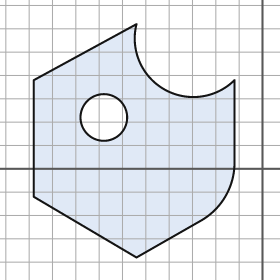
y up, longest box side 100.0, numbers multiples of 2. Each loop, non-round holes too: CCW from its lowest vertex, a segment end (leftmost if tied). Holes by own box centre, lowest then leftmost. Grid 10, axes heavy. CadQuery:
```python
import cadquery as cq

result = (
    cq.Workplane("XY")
    .moveTo(-54.0, -38.0)
    .lineTo(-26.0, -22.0)
    .threePointArc((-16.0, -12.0), (-12.0, 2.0))
    .lineTo(-12.0, 38.0)
    .threePointArc((-42.0, 34.0), (-54.0, 62.0))
    .lineTo(-98.0, 38.0)
    .lineTo(-98.0, -12.0)
    .close()
    .moveTo(-68.0, 22.0)
    .circle(10.0)
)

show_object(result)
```